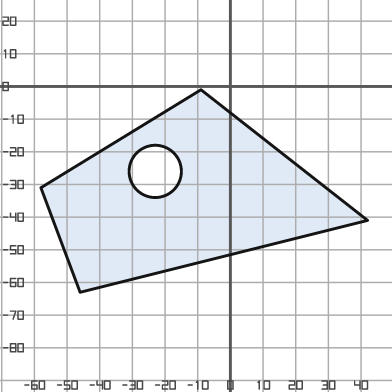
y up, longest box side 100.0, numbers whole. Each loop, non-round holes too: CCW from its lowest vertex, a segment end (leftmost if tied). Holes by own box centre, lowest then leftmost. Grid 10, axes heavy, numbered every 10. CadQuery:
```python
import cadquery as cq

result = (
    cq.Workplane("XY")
    .moveTo(-46.0, -63.0)
    .lineTo(42.0, -41.0)
    .lineTo(-9.0, -1.0)
    .lineTo(-58.0, -31.0)
    .close()
    .moveTo(-23.0, -26.0)
    .circle(8.0)
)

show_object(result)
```